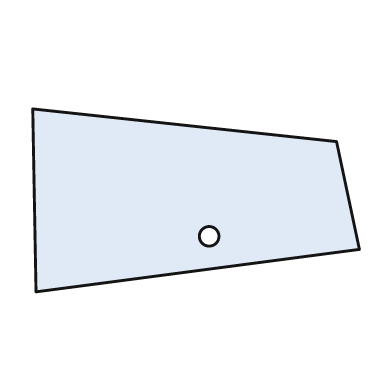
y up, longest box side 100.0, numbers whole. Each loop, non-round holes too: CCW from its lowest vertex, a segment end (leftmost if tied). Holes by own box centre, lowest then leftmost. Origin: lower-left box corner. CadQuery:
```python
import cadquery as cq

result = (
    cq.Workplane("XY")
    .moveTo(1.0, 0.0)
    .lineTo(100.0, 13.0)
    .lineTo(93.0, 46.0)
    .lineTo(0.0, 56.0)
    .close()
    .moveTo(54.0, 17.0)
    .circle(3.0)
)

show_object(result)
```